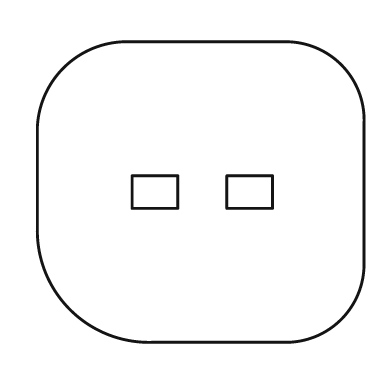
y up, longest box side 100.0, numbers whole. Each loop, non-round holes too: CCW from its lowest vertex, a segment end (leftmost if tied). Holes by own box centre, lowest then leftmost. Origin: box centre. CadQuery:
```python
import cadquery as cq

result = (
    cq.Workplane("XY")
    .moveTo(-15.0, -46.0)
    .lineTo(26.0, -46.0)
    .threePointArc((43.0, -39.0), (50.0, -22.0))
    .lineTo(50.0, 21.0)
    .threePointArc((43.0, 39.0), (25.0, 46.0))
    .lineTo(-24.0, 46.0)
    .threePointArc((-42.0, 38.0), (-50.0, 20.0))
    .lineTo(-50.0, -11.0)
    .threePointArc((-40.0, -36.0), (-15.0, -46.0))
    .close()
    .moveTo(-21.0, -5.0)
    .lineTo(-7.0, -5.0)
    .lineTo(-7.0, 5.0)
    .lineTo(-21.0, 5.0)
    .close()
    .moveTo(8.0, -5.0)
    .lineTo(22.0, -5.0)
    .lineTo(22.0, 5.0)
    .lineTo(8.0, 5.0)
    .close()
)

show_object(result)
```